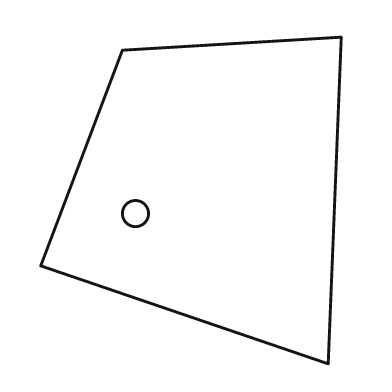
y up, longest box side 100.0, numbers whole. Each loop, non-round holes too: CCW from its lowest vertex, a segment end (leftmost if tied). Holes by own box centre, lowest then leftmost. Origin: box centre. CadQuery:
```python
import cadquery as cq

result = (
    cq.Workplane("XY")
    .moveTo(42.0, -50.0)
    .lineTo(46.0, 50.0)
    .lineTo(-21.0, 46.0)
    .lineTo(-46.0, -20.0)
    .close()
    .moveTo(-17.0, -4.0)
    .circle(4.0)
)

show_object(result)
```